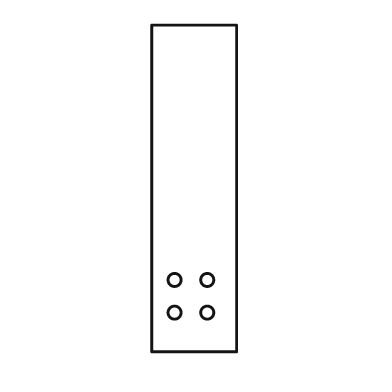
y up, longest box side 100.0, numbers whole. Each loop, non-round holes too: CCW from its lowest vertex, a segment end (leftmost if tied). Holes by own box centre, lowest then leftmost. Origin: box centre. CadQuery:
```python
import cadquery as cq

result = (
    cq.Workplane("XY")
    .moveTo(-13.0, -50.0)
    .lineTo(13.0, -50.0)
    .lineTo(13.0, 50.0)
    .lineTo(-13.0, 50.0)
    .close()
    .moveTo(-6.0, -38.0)
    .circle(2.0)
    .moveTo(4.0, -38.0)
    .circle(2.0)
    .moveTo(-6.0, -28.0)
    .circle(2.0)
    .moveTo(4.0, -28.0)
    .circle(2.0)
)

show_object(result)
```